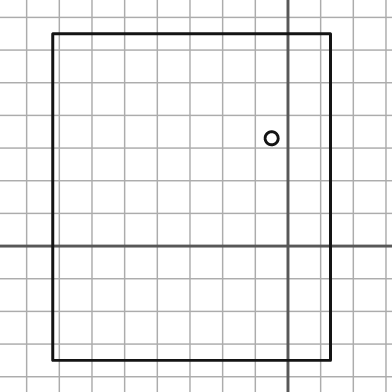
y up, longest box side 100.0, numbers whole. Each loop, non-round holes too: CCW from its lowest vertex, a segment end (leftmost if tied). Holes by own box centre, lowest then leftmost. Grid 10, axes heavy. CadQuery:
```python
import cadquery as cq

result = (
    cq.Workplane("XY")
    .moveTo(-72.0, -35.0)
    .lineTo(13.0, -35.0)
    .lineTo(13.0, 65.0)
    .lineTo(-72.0, 65.0)
    .close()
    .moveTo(-5.0, 33.0)
    .circle(2.0)
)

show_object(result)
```